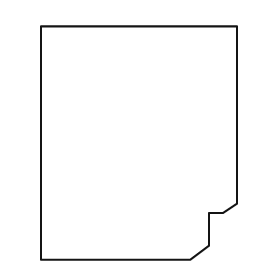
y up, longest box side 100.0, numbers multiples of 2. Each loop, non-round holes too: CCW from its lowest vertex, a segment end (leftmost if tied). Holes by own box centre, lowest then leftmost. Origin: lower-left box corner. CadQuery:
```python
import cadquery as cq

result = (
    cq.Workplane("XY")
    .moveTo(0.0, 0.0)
    .lineTo(64.0, 0.0)
    .lineTo(72.0, 6.0)
    .lineTo(72.0, 20.0)
    .lineTo(78.0, 20.0)
    .lineTo(84.0, 24.0)
    .lineTo(84.0, 100.0)
    .lineTo(0.0, 100.0)
    .close()
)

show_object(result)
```